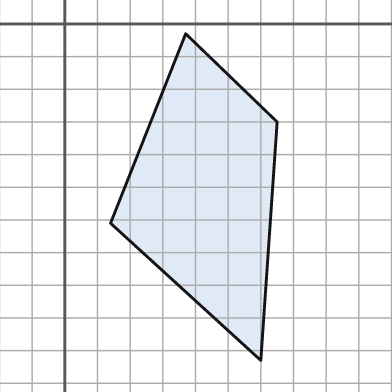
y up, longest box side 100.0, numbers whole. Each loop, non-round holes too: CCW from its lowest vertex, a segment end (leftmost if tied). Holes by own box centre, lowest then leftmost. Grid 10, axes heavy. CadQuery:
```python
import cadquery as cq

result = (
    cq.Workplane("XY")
    .moveTo(60.0, -103.0)
    .lineTo(65.0, -30.0)
    .lineTo(37.0, -3.0)
    .lineTo(14.0, -61.0)
    .close()
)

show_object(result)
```